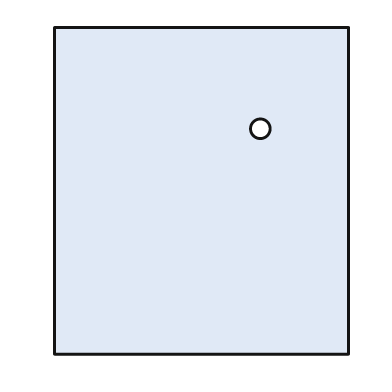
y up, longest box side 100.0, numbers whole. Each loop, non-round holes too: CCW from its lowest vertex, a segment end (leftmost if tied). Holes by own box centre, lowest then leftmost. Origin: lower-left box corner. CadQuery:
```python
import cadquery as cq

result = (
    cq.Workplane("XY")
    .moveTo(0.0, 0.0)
    .lineTo(90.0, 0.0)
    .lineTo(90.0, 100.0)
    .lineTo(0.0, 100.0)
    .close()
    .moveTo(63.0, 69.0)
    .circle(3.0)
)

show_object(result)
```